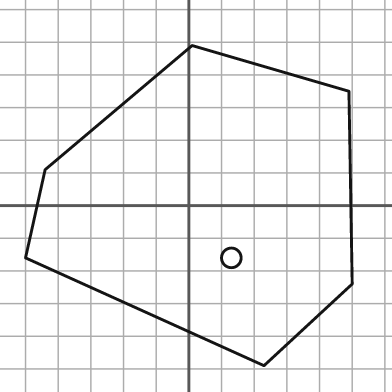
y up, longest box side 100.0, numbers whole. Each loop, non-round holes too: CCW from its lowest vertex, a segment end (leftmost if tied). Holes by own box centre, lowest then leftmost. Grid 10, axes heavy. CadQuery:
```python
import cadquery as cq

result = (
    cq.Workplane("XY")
    .moveTo(23.0, -49.0)
    .lineTo(50.0, -24.0)
    .lineTo(49.0, 35.0)
    .lineTo(1.0, 49.0)
    .lineTo(-44.0, 11.0)
    .lineTo(-50.0, -16.0)
    .close()
    .moveTo(13.0, -16.0)
    .circle(3.0)
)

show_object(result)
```